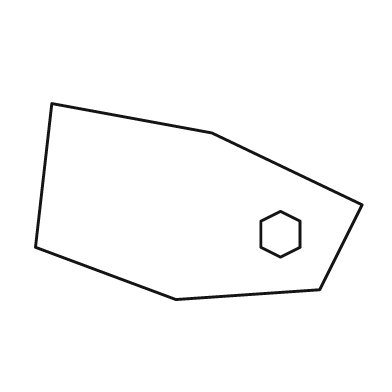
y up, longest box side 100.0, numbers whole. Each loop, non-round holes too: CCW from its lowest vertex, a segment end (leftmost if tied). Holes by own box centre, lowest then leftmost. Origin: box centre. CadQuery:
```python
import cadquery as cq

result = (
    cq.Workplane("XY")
    .moveTo(-7.0, -30.0)
    .lineTo(37.0, -27.0)
    .lineTo(50.0, -1.0)
    .lineTo(4.0, 21.0)
    .lineTo(-45.0, 30.0)
    .lineTo(-50.0, -14.0)
    .close()
    .moveTo(25.0, -17.0)
    .lineTo(31.0, -14.0)
    .lineTo(31.0, -6.0)
    .lineTo(25.0, -3.0)
    .lineTo(19.0, -6.0)
    .lineTo(19.0, -14.0)
    .close()
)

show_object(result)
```